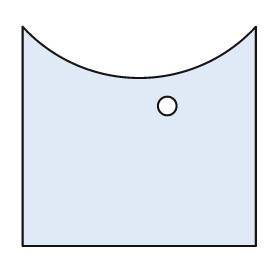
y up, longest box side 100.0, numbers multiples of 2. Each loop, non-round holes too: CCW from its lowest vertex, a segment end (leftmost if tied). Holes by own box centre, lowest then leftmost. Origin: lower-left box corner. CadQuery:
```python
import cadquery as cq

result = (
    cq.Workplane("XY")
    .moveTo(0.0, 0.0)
    .lineTo(100.0, 0.0)
    .lineTo(100.0, 94.0)
    .threePointArc((50.0, 72.0), (0.0, 94.0))
    .close()
    .moveTo(62.0, 60.0)
    .circle(4.0)
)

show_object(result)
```